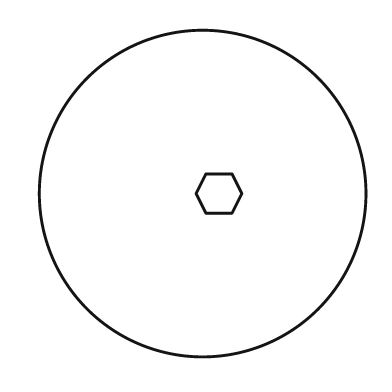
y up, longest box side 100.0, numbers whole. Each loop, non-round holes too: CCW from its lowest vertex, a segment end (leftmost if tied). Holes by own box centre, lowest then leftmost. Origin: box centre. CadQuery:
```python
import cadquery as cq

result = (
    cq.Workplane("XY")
    .moveTo(0.0, 0.0)
    .circle(50.0)
    .moveTo(1.0, -6.0)
    .lineTo(9.0, -6.0)
    .lineTo(12.0, 0.0)
    .lineTo(9.0, 6.0)
    .lineTo(1.0, 6.0)
    .lineTo(-2.0, 0.0)
    .close()
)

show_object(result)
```